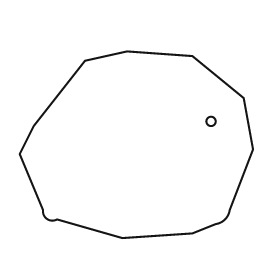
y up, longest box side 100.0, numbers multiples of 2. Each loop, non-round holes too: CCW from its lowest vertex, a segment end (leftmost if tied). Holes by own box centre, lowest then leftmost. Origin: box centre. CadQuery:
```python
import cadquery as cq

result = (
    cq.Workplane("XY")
    .moveTo(-6.0, -40.0)
    .lineTo(24.0, -38.0)
    .lineTo(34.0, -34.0)
    .threePointArc((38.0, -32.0), (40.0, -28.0))
    .lineTo(50.0, -2.0)
    .lineTo(46.0, 20.0)
    .lineTo(24.0, 38.0)
    .lineTo(-4.0, 40.0)
    .lineTo(-22.0, 36.0)
    .lineTo(-44.0, 8.0)
    .lineTo(-50.0, -4.0)
    .lineTo(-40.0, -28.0)
    .threePointArc((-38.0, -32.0), (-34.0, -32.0))
    .close()
    .moveTo(32.0, 10.0)
    .circle(2.0)
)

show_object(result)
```